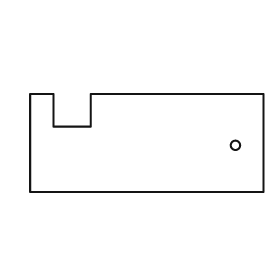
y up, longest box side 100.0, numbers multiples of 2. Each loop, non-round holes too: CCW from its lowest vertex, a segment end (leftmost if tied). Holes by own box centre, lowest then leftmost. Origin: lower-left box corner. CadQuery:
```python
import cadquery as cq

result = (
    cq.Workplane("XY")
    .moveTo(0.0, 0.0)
    .lineTo(100.0, 0.0)
    .lineTo(100.0, 42.0)
    .lineTo(26.0, 42.0)
    .lineTo(26.0, 28.0)
    .lineTo(10.0, 28.0)
    .lineTo(10.0, 42.0)
    .lineTo(0.0, 42.0)
    .close()
    .moveTo(88.0, 20.0)
    .circle(2.0)
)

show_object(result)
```